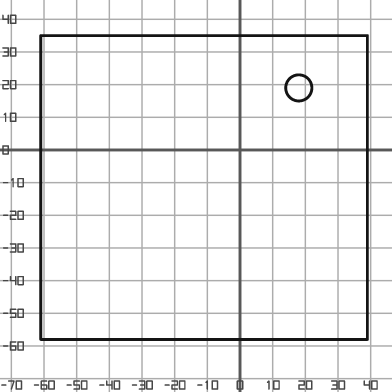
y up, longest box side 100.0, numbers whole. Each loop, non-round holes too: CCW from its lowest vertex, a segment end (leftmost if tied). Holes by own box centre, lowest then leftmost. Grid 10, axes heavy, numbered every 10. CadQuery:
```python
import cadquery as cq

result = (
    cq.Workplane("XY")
    .moveTo(-61.0, -58.0)
    .lineTo(39.0, -58.0)
    .lineTo(39.0, 35.0)
    .lineTo(-61.0, 35.0)
    .close()
    .moveTo(18.0, 19.0)
    .circle(4.0)
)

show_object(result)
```